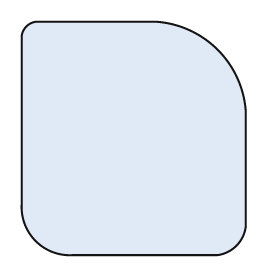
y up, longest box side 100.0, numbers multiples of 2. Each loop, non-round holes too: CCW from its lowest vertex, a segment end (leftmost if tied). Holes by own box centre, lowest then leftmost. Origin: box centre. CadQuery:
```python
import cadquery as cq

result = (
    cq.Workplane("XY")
    .moveTo(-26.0, -50.0)
    .lineTo(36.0, -50.0)
    .threePointArc((44.0, -46.0), (48.0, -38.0))
    .lineTo(48.0, 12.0)
    .threePointArc((36.0, 38.0), (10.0, 50.0))
    .lineTo(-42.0, 50.0)
    .threePointArc((-46.0, 48.0), (-48.0, 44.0))
    .lineTo(-48.0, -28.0)
    .threePointArc((-42.0, -44.0), (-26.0, -50.0))
    .close()
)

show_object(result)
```